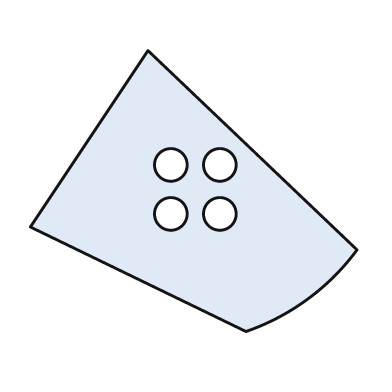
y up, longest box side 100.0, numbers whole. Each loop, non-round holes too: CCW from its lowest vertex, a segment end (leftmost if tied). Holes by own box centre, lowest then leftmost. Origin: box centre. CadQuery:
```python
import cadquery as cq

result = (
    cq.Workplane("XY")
    .moveTo(16.0, -43.0)
    .threePointArc((35.0, -33.0), (50.0, -18.0))
    .lineTo(-14.0, 43.0)
    .lineTo(-50.0, -11.0)
    .close()
    .moveTo(-7.0, -7.0)
    .circle(5.0)
    .moveTo(8.0, -7.0)
    .circle(5.0)
    .moveTo(-7.0, 8.0)
    .circle(5.0)
    .moveTo(8.0, 8.0)
    .circle(5.0)
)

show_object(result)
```